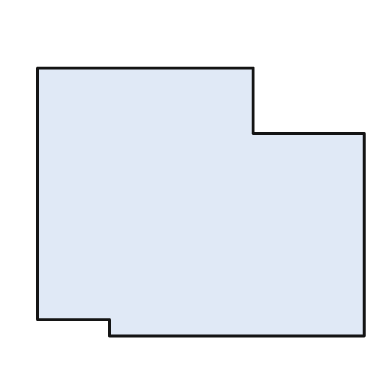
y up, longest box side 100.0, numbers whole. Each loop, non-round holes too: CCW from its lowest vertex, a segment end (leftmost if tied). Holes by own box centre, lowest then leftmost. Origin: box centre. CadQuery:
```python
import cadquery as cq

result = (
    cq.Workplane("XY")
    .moveTo(-28.0, -41.0)
    .lineTo(50.0, -41.0)
    .lineTo(50.0, 21.0)
    .lineTo(16.0, 21.0)
    .lineTo(16.0, 41.0)
    .lineTo(-50.0, 41.0)
    .lineTo(-50.0, -36.0)
    .lineTo(-28.0, -36.0)
    .close()
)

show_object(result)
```